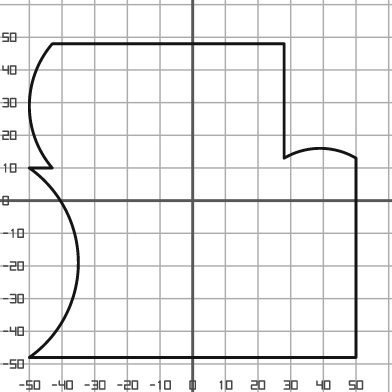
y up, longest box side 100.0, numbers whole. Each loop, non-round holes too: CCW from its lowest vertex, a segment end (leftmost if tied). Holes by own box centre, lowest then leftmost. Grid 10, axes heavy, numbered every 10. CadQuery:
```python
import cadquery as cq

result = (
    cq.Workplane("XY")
    .moveTo(-50.0, -48.0)
    .lineTo(50.0, -48.0)
    .lineTo(50.0, 13.0)
    .threePointArc((39.0, 16.0), (28.0, 13.0))
    .lineTo(28.0, 48.0)
    .lineTo(-43.0, 48.0)
    .threePointArc((-50.0, 29.0), (-43.0, 10.0))
    .lineTo(-50.0, 10.0)
    .threePointArc((-35.0, -19.0), (-50.0, -48.0))
    .close()
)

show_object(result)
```